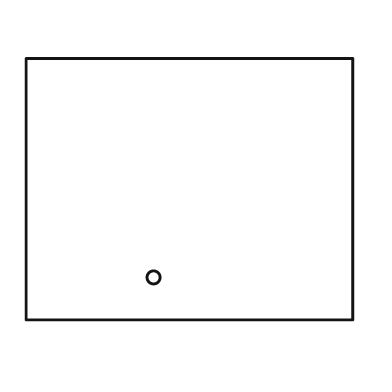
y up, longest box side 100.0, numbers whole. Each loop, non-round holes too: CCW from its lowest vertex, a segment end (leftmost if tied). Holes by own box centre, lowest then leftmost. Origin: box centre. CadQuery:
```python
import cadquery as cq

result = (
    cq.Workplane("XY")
    .moveTo(-50.0, -40.0)
    .lineTo(50.0, -40.0)
    .lineTo(50.0, 40.0)
    .lineTo(-50.0, 40.0)
    .close()
    .moveTo(-11.0, -27.0)
    .circle(2.0)
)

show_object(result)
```